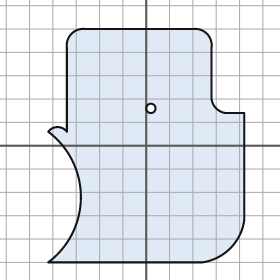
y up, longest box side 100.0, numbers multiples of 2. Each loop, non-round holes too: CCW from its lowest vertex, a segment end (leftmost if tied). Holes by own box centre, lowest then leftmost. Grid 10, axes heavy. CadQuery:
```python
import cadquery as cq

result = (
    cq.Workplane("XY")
    .moveTo(-42.0, -50.0)
    .lineTo(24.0, -50.0)
    .threePointArc((36.0, -44.0), (42.0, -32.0))
    .lineTo(42.0, 14.0)
    .lineTo(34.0, 14.0)
    .threePointArc((30.0, 16.0), (28.0, 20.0))
    .lineTo(28.0, 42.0)
    .threePointArc((26.0, 48.0), (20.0, 50.0))
    .lineTo(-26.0, 50.0)
    .threePointArc((-32.0, 48.0), (-34.0, 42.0))
    .lineTo(-34.0, 6.0)
    .threePointArc((-38.0, 8.0), (-42.0, 6.0))
    .threePointArc((-28.0, -22.0), (-42.0, -50.0))
    .close()
    .moveTo(2.0, 16.0)
    .circle(2.0)
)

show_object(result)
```